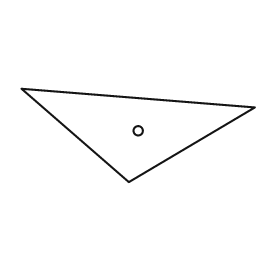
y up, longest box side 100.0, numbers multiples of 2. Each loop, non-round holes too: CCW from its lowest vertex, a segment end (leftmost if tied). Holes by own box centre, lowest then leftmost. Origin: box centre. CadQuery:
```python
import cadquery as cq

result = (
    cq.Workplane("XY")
    .moveTo(-4.0, -20.0)
    .lineTo(50.0, 12.0)
    .lineTo(-50.0, 20.0)
    .close()
    .moveTo(0.0, 2.0)
    .circle(2.0)
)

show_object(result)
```